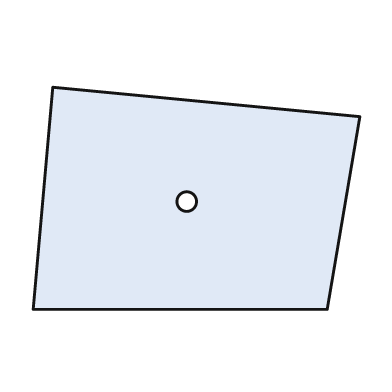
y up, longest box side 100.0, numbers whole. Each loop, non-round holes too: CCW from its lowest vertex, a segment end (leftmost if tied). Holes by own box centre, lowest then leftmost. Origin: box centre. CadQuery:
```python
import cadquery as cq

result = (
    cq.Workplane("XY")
    .moveTo(-50.0, -34.0)
    .lineTo(40.0, -34.0)
    .lineTo(50.0, 25.0)
    .lineTo(-44.0, 34.0)
    .close()
    .moveTo(-3.0, -1.0)
    .circle(3.0)
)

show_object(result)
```